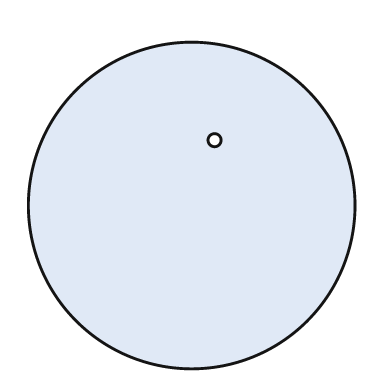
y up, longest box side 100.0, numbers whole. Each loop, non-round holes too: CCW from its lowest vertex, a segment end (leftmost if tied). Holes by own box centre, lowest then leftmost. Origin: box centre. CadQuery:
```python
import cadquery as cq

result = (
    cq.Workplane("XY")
    .moveTo(0.0, 0.0)
    .circle(50.0)
    .moveTo(7.0, 20.0)
    .circle(2.0)
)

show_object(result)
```